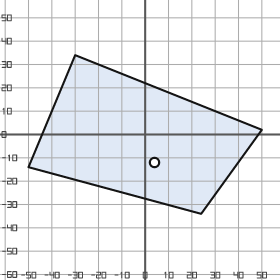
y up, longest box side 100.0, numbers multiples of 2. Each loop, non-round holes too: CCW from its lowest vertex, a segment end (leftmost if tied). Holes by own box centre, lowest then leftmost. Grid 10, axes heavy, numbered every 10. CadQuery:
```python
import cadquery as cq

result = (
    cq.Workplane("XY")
    .moveTo(24.0, -34.0)
    .lineTo(50.0, 2.0)
    .lineTo(-30.0, 34.0)
    .lineTo(-50.0, -14.0)
    .close()
    .moveTo(4.0, -12.0)
    .circle(2.0)
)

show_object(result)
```